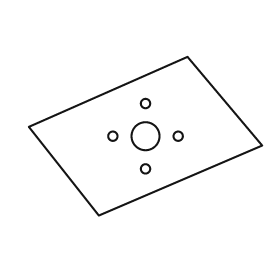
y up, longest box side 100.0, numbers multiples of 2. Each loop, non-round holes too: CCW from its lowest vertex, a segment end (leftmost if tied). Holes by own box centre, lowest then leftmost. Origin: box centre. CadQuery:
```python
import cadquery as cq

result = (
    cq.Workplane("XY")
    .moveTo(-20.0, -34.0)
    .lineTo(50.0, -4.0)
    .lineTo(18.0, 34.0)
    .lineTo(-50.0, 4.0)
    .close()
    .moveTo(0.0, -14.0)
    .circle(2.0)
    .moveTo(-14.0, 0.0)
    .circle(2.0)
    .moveTo(0.0, 0.0)
    .circle(6.0)
    .moveTo(14.0, 0.0)
    .circle(2.0)
    .moveTo(0.0, 14.0)
    .circle(2.0)
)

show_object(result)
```